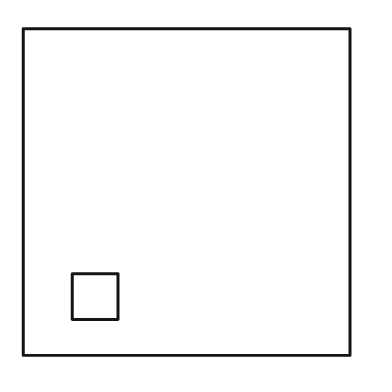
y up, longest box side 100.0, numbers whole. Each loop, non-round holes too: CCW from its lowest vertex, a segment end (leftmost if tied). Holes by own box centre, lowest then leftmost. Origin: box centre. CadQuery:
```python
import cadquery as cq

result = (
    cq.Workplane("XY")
    .moveTo(-50.0, -50.0)
    .lineTo(50.0, -50.0)
    .lineTo(50.0, 50.0)
    .lineTo(-50.0, 50.0)
    .close()
    .moveTo(-35.0, -39.0)
    .lineTo(-21.0, -39.0)
    .lineTo(-21.0, -25.0)
    .lineTo(-35.0, -25.0)
    .close()
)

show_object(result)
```